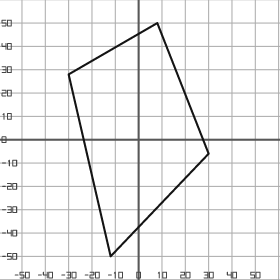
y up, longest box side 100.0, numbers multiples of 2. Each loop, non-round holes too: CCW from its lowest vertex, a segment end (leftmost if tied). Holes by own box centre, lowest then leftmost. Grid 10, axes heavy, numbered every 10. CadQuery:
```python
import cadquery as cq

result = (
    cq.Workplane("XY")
    .moveTo(-12.0, -50.0)
    .lineTo(30.0, -6.0)
    .lineTo(8.0, 50.0)
    .lineTo(-30.0, 28.0)
    .close()
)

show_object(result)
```